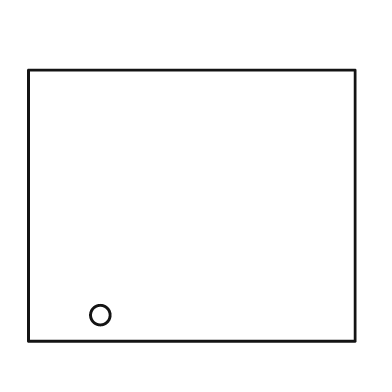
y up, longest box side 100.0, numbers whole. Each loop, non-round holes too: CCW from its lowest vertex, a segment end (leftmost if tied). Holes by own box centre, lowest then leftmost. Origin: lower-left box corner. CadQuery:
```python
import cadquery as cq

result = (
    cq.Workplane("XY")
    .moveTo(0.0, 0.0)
    .lineTo(100.0, 0.0)
    .lineTo(100.0, 83.0)
    .lineTo(0.0, 83.0)
    .close()
    .moveTo(22.0, 8.0)
    .circle(3.0)
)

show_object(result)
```